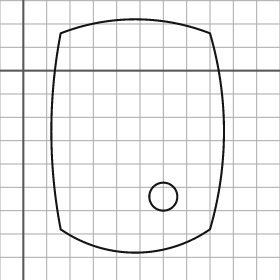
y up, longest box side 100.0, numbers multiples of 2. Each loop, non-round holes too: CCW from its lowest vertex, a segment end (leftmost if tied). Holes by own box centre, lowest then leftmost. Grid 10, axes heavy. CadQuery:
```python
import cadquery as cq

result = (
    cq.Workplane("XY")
    .moveTo(16.0, -68.0)
    .threePointArc((48.0, -78.0), (80.0, -68.0))
    .threePointArc((86.0, -26.0), (80.0, 16.0))
    .threePointArc((48.0, 22.0), (16.0, 16.0))
    .threePointArc((12.0, -26.0), (16.0, -68.0))
    .close()
    .moveTo(60.0, -54.0)
    .circle(6.0)
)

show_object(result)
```